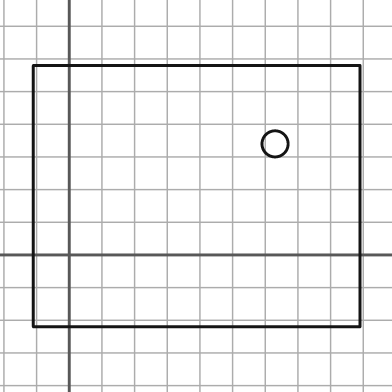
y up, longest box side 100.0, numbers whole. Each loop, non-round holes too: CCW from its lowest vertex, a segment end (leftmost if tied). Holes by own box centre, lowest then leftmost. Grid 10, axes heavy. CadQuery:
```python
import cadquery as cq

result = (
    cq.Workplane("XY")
    .moveTo(-11.0, -22.0)
    .lineTo(89.0, -22.0)
    .lineTo(89.0, 58.0)
    .lineTo(-11.0, 58.0)
    .close()
    .moveTo(63.0, 34.0)
    .circle(4.0)
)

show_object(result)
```